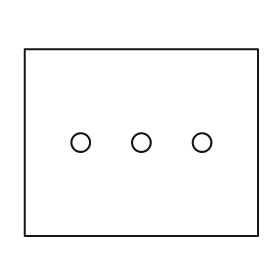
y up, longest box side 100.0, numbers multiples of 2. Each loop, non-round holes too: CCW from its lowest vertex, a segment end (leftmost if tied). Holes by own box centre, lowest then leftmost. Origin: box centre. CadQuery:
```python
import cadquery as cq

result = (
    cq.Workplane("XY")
    .moveTo(-50.0, -40.0)
    .lineTo(50.0, -40.0)
    .lineTo(50.0, 40.0)
    .lineTo(-50.0, 40.0)
    .close()
    .moveTo(-26.0, 0.0)
    .circle(4.0)
    .moveTo(0.0, 0.0)
    .circle(4.0)
    .moveTo(26.0, 0.0)
    .circle(4.0)
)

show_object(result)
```